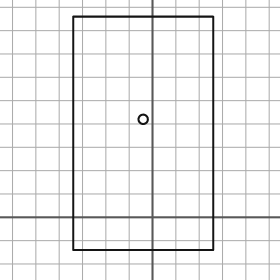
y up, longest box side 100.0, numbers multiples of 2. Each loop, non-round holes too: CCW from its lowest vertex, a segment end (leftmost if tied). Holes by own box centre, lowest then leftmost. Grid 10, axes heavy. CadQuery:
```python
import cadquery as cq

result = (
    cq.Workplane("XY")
    .moveTo(-34.0, -14.0)
    .lineTo(26.0, -14.0)
    .lineTo(26.0, 86.0)
    .lineTo(-34.0, 86.0)
    .close()
    .moveTo(-4.0, 42.0)
    .circle(2.0)
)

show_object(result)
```